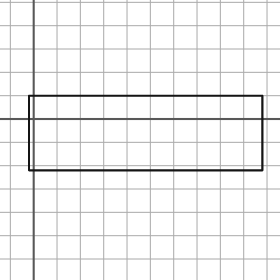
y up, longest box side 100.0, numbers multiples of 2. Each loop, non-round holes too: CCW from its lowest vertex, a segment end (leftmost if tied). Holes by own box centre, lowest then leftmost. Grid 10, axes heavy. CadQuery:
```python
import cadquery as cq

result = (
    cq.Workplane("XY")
    .moveTo(-2.0, -22.0)
    .lineTo(98.0, -22.0)
    .lineTo(98.0, 10.0)
    .lineTo(-2.0, 10.0)
    .close()
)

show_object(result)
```